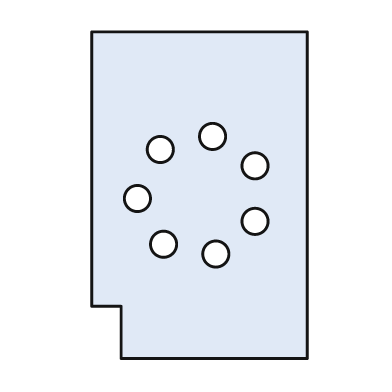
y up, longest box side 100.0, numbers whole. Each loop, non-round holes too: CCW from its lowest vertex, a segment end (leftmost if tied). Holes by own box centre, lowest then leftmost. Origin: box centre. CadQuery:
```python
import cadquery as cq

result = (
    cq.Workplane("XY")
    .moveTo(-24.0, -50.0)
    .lineTo(33.0, -50.0)
    .lineTo(33.0, 50.0)
    .lineTo(-33.0, 50.0)
    .lineTo(-33.0, -34.0)
    .lineTo(-24.0, -34.0)
    .close()
    .moveTo(5.0, -18.0)
    .circle(4.0)
    .moveTo(-11.0, -15.0)
    .circle(4.0)
    .moveTo(17.0, -8.0)
    .circle(4.0)
    .moveTo(-19.0, -1.0)
    .circle(4.0)
    .moveTo(17.0, 9.0)
    .circle(4.0)
    .moveTo(-12.0, 14.0)
    .circle(4.0)
    .moveTo(4.0, 18.0)
    .circle(4.0)
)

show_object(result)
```